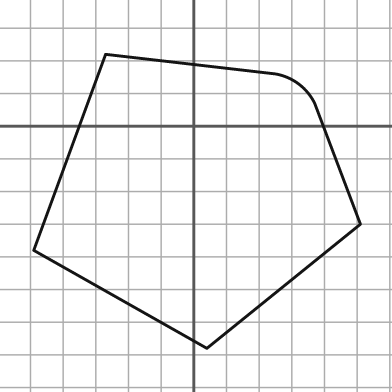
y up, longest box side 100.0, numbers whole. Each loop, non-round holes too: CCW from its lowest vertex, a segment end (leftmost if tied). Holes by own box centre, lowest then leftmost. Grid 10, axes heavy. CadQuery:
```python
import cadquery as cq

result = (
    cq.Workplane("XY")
    .moveTo(4.0, -68.0)
    .lineTo(51.0, -30.0)
    .lineTo(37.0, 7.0)
    .threePointArc((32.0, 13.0), (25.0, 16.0))
    .lineTo(-27.0, 22.0)
    .lineTo(-49.0, -38.0)
    .close()
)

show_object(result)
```